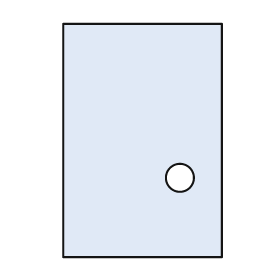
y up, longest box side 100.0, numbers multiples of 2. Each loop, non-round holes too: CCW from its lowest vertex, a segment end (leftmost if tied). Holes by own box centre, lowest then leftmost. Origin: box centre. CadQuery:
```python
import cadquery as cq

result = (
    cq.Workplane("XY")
    .moveTo(-34.0, -50.0)
    .lineTo(34.0, -50.0)
    .lineTo(34.0, 50.0)
    .lineTo(-34.0, 50.0)
    .close()
    .moveTo(16.0, -16.0)
    .circle(6.0)
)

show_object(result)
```